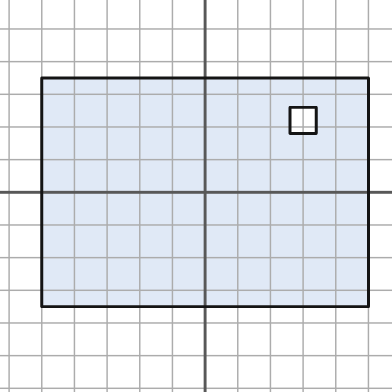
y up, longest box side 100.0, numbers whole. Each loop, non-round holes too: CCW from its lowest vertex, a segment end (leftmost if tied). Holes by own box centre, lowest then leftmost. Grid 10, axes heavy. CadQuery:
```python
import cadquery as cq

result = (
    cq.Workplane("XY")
    .moveTo(-50.0, -35.0)
    .lineTo(50.0, -35.0)
    .lineTo(50.0, 35.0)
    .lineTo(-50.0, 35.0)
    .close()
    .moveTo(26.0, 18.0)
    .lineTo(34.0, 18.0)
    .lineTo(34.0, 26.0)
    .lineTo(26.0, 26.0)
    .close()
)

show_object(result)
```